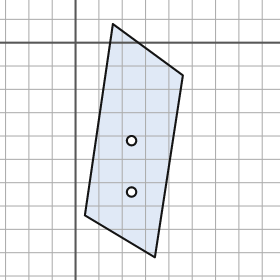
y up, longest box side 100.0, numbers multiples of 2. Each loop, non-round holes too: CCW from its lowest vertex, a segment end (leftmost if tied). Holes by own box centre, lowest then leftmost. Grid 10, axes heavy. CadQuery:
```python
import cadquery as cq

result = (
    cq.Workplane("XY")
    .moveTo(34.0, -92.0)
    .lineTo(46.0, -14.0)
    .lineTo(16.0, 8.0)
    .lineTo(4.0, -74.0)
    .close()
    .moveTo(24.0, -64.0)
    .circle(2.0)
    .moveTo(24.0, -42.0)
    .circle(2.0)
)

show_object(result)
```